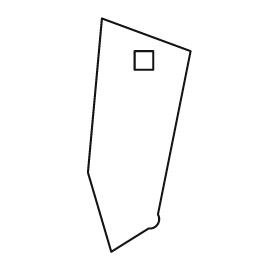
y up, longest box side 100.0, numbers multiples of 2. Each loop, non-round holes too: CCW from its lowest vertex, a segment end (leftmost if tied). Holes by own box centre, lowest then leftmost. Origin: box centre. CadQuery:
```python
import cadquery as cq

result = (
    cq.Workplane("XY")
    .moveTo(-12.0, -50.0)
    .lineTo(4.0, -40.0)
    .threePointArc((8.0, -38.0), (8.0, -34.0))
    .lineTo(22.0, 36.0)
    .lineTo(-16.0, 50.0)
    .lineTo(-22.0, -16.0)
    .close()
    .moveTo(-2.0, 28.0)
    .lineTo(6.0, 28.0)
    .lineTo(6.0, 36.0)
    .lineTo(-2.0, 36.0)
    .close()
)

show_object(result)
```